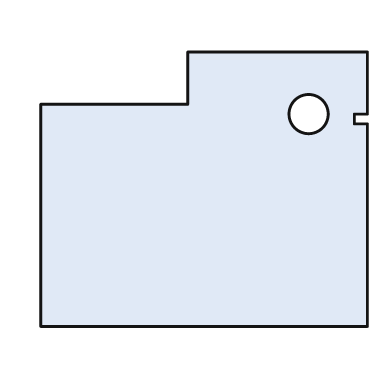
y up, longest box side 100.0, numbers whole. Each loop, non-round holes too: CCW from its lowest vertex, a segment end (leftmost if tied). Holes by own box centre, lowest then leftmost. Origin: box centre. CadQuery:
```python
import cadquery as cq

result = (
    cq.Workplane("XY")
    .moveTo(-50.0, -42.0)
    .lineTo(50.0, -42.0)
    .lineTo(50.0, 20.0)
    .lineTo(46.0, 20.0)
    .lineTo(46.0, 23.0)
    .lineTo(50.0, 23.0)
    .lineTo(50.0, 42.0)
    .lineTo(-5.0, 42.0)
    .lineTo(-5.0, 26.0)
    .lineTo(-50.0, 26.0)
    .close()
    .moveTo(32.0, 23.0)
    .circle(6.0)
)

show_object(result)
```